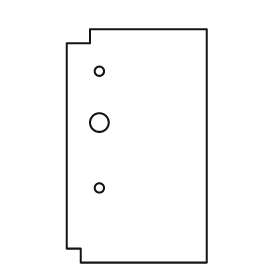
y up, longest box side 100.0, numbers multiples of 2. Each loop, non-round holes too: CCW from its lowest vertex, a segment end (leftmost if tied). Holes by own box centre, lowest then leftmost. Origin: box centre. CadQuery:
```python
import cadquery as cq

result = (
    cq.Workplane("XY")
    .moveTo(-24.0, -50.0)
    .lineTo(30.0, -50.0)
    .lineTo(30.0, 50.0)
    .lineTo(-20.0, 50.0)
    .lineTo(-20.0, 44.0)
    .lineTo(-30.0, 44.0)
    .lineTo(-30.0, -44.0)
    .lineTo(-24.0, -44.0)
    .close()
    .moveTo(-16.0, -18.0)
    .circle(2.0)
    .moveTo(-16.0, 10.0)
    .circle(4.0)
    .moveTo(-16.0, 32.0)
    .circle(2.0)
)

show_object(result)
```